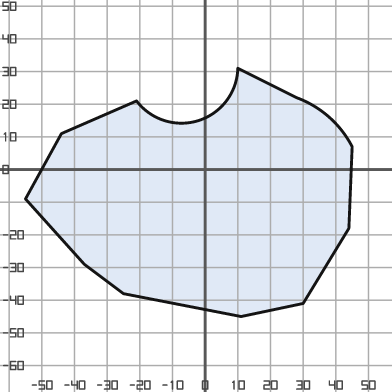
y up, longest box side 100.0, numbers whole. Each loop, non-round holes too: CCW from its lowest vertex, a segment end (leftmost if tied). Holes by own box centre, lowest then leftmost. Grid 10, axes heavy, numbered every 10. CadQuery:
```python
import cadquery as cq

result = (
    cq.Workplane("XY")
    .moveTo(11.0, -45.0)
    .lineTo(30.0, -41.0)
    .lineTo(44.0, -18.0)
    .lineTo(45.0, 7.0)
    .threePointArc((38.0, 16.0), (28.0, 22.0))
    .lineTo(10.0, 31.0)
    .threePointArc((-2.0, 15.0), (-21.0, 21.0))
    .lineTo(-44.0, 11.0)
    .lineTo(-55.0, -9.0)
    .lineTo(-37.0, -29.0)
    .lineTo(-25.0, -38.0)
    .close()
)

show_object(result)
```